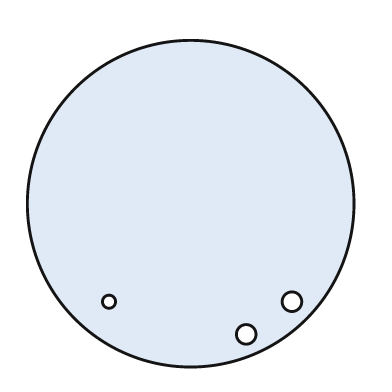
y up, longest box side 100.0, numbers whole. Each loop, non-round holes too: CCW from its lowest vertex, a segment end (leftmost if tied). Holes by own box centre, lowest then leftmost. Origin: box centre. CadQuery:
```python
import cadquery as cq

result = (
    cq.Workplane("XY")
    .moveTo(0.0, 0.0)
    .circle(50.0)
    .moveTo(17.0, -40.0)
    .circle(3.0)
    .moveTo(-25.0, -30.0)
    .circle(2.0)
    .moveTo(31.0, -30.0)
    .circle(3.0)
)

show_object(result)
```